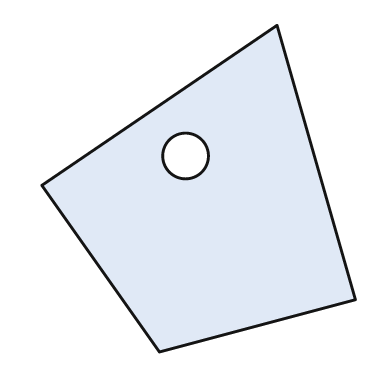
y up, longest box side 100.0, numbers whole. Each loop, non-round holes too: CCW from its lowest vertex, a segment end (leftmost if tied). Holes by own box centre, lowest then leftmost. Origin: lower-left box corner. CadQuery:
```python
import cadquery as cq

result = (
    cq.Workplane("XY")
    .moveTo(36.0, 0.0)
    .lineTo(96.0, 16.0)
    .lineTo(72.0, 100.0)
    .lineTo(0.0, 51.0)
    .close()
    .moveTo(44.0, 60.0)
    .circle(7.0)
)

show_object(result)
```